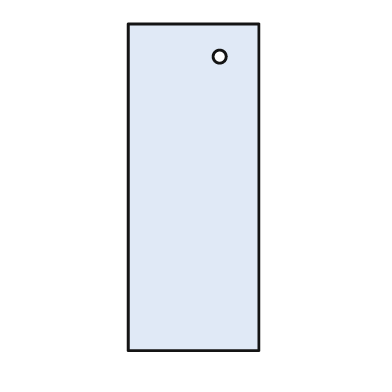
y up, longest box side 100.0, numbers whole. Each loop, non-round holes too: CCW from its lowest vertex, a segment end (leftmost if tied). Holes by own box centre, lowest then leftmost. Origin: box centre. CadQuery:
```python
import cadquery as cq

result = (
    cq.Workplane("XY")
    .moveTo(-20.0, -50.0)
    .lineTo(20.0, -50.0)
    .lineTo(20.0, 50.0)
    .lineTo(-20.0, 50.0)
    .close()
    .moveTo(8.0, 40.0)
    .circle(2.0)
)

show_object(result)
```